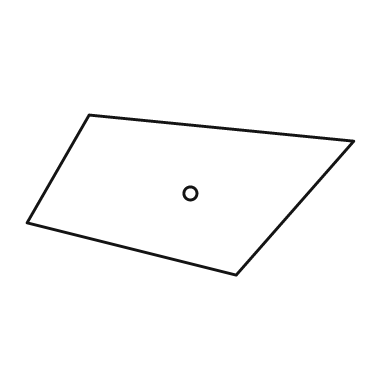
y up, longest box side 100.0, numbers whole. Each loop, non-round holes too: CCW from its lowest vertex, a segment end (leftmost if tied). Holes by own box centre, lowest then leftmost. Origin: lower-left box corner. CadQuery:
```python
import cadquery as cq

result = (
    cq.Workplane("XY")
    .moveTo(64.0, 0.0)
    .lineTo(100.0, 41.0)
    .lineTo(19.0, 49.0)
    .lineTo(0.0, 16.0)
    .close()
    .moveTo(50.0, 25.0)
    .circle(2.0)
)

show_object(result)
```